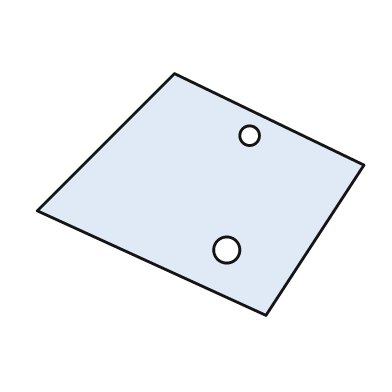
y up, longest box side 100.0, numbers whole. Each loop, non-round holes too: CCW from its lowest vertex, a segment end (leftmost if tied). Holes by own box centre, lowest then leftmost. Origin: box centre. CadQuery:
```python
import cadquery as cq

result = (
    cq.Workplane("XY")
    .moveTo(20.0, -37.0)
    .lineTo(50.0, 9.0)
    .lineTo(-8.0, 37.0)
    .lineTo(-50.0, -5.0)
    .close()
    .moveTo(8.0, -17.0)
    .circle(4.0)
    .moveTo(15.0, 18.0)
    .circle(3.0)
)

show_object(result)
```